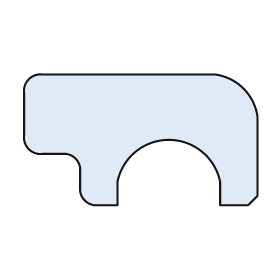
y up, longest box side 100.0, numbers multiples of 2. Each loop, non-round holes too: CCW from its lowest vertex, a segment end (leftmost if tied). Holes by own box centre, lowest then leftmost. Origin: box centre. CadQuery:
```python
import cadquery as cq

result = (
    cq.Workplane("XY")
    .moveTo(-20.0, -28.0)
    .lineTo(-10.0, -28.0)
    .lineTo(-10.0, -18.0)
    .threePointArc((12.0, 0.0), (34.0, -18.0))
    .lineTo(34.0, -28.0)
    .lineTo(46.0, -28.0)
    .lineTo(50.0, -24.0)
    .lineTo(50.0, 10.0)
    .threePointArc((44.0, 22.0), (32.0, 28.0))
    .lineTo(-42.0, 28.0)
    .threePointArc((-48.0, 26.0), (-50.0, 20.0))
    .lineTo(-50.0, 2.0)
    .threePointArc((-48.0, -4.0), (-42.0, -6.0))
    .lineTo(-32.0, -6.0)
    .threePointArc((-28.0, -8.0), (-26.0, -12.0))
    .lineTo(-26.0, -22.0)
    .threePointArc((-24.0, -26.0), (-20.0, -28.0))
    .close()
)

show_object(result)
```